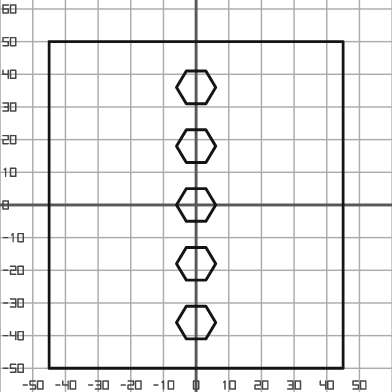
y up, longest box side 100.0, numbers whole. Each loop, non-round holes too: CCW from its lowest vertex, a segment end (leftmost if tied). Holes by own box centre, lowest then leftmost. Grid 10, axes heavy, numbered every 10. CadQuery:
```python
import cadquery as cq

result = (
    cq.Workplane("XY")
    .moveTo(-45.0, -50.0)
    .lineTo(45.0, -50.0)
    .lineTo(45.0, 50.0)
    .lineTo(-45.0, 50.0)
    .close()
    .moveTo(-3.0, -41.0)
    .lineTo(3.0, -41.0)
    .lineTo(6.0, -36.0)
    .lineTo(3.0, -31.0)
    .lineTo(-3.0, -31.0)
    .lineTo(-6.0, -36.0)
    .close()
    .moveTo(-3.0, -23.0)
    .lineTo(3.0, -23.0)
    .lineTo(6.0, -18.0)
    .lineTo(3.0, -13.0)
    .lineTo(-3.0, -13.0)
    .lineTo(-6.0, -18.0)
    .close()
    .moveTo(-3.0, -5.0)
    .lineTo(3.0, -5.0)
    .lineTo(6.0, 0.0)
    .lineTo(3.0, 5.0)
    .lineTo(-3.0, 5.0)
    .lineTo(-6.0, 0.0)
    .close()
    .moveTo(-3.0, 13.0)
    .lineTo(3.0, 13.0)
    .lineTo(6.0, 18.0)
    .lineTo(3.0, 23.0)
    .lineTo(-3.0, 23.0)
    .lineTo(-6.0, 18.0)
    .close()
    .moveTo(-3.0, 31.0)
    .lineTo(3.0, 31.0)
    .lineTo(6.0, 36.0)
    .lineTo(3.0, 41.0)
    .lineTo(-3.0, 41.0)
    .lineTo(-6.0, 36.0)
    .close()
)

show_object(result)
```